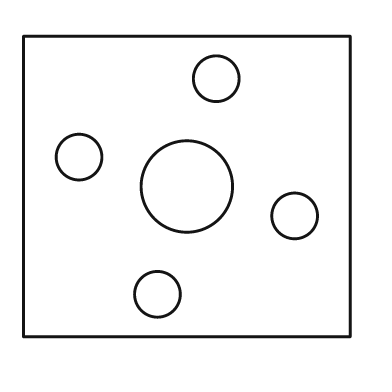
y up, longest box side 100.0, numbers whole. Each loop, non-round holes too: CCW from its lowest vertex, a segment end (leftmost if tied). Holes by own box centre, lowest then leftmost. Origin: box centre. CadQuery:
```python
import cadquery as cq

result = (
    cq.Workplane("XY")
    .moveTo(-50.0, -46.0)
    .lineTo(50.0, -46.0)
    .lineTo(50.0, 46.0)
    .lineTo(-50.0, 46.0)
    .close()
    .moveTo(-9.0, -33.0)
    .circle(7.0)
    .moveTo(33.0, -9.0)
    .circle(7.0)
    .moveTo(0.0, 0.0)
    .circle(14.0)
    .moveTo(-33.0, 9.0)
    .circle(7.0)
    .moveTo(9.0, 33.0)
    .circle(7.0)
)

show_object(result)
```